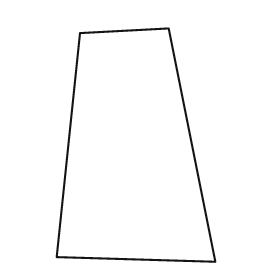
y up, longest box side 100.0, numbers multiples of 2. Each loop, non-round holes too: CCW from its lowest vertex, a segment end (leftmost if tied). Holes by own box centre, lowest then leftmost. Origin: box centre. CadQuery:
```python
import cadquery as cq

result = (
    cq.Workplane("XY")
    .moveTo(34.0, -50.0)
    .lineTo(14.0, 50.0)
    .lineTo(-24.0, 48.0)
    .lineTo(-34.0, -48.0)
    .close()
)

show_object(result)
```